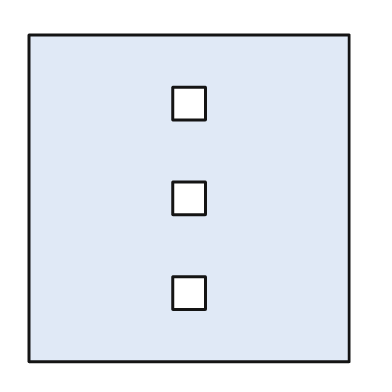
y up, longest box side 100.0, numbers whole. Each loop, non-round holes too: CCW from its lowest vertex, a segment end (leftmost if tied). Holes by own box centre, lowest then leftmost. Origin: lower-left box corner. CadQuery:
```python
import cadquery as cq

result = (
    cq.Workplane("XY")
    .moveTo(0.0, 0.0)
    .lineTo(98.0, 0.0)
    .lineTo(98.0, 100.0)
    .lineTo(0.0, 100.0)
    .close()
    .moveTo(44.0, 16.0)
    .lineTo(54.0, 16.0)
    .lineTo(54.0, 26.0)
    .lineTo(44.0, 26.0)
    .close()
    .moveTo(44.0, 45.0)
    .lineTo(54.0, 45.0)
    .lineTo(54.0, 55.0)
    .lineTo(44.0, 55.0)
    .close()
    .moveTo(44.0, 74.0)
    .lineTo(54.0, 74.0)
    .lineTo(54.0, 84.0)
    .lineTo(44.0, 84.0)
    .close()
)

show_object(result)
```